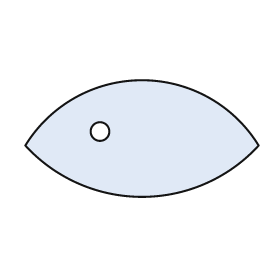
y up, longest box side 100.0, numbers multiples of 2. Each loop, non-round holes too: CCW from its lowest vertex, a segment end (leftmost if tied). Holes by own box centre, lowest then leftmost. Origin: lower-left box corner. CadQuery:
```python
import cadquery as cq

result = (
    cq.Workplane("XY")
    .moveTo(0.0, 22.0)
    .threePointArc((50.0, 0.0), (100.0, 22.0))
    .threePointArc((50.0, 50.0), (0.0, 22.0))
    .close()
    .moveTo(32.0, 28.0)
    .circle(4.0)
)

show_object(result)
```